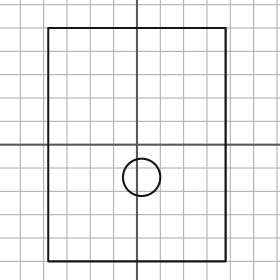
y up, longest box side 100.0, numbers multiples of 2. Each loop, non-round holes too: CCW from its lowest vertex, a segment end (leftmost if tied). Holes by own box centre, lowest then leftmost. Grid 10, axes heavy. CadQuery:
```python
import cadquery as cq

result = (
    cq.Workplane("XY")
    .moveTo(-38.0, -50.0)
    .lineTo(38.0, -50.0)
    .lineTo(38.0, 50.0)
    .lineTo(-38.0, 50.0)
    .close()
    .moveTo(2.0, -14.0)
    .circle(8.0)
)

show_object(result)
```